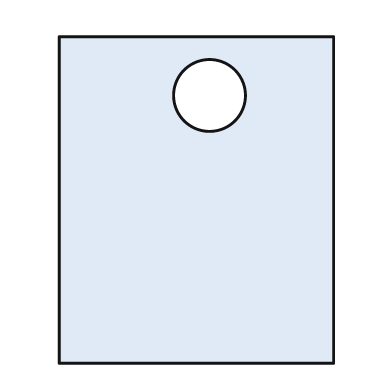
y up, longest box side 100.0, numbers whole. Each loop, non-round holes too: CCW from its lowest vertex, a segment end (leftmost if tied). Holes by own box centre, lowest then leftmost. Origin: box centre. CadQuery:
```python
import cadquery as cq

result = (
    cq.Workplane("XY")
    .moveTo(-42.0, -50.0)
    .lineTo(42.0, -50.0)
    .lineTo(42.0, 50.0)
    .lineTo(-42.0, 50.0)
    .close()
    .moveTo(4.0, 32.0)
    .circle(11.0)
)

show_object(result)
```